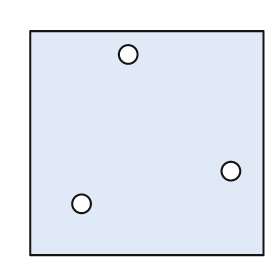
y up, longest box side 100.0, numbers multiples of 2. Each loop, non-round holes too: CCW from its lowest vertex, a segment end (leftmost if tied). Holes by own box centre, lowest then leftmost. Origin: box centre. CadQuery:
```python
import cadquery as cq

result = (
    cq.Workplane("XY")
    .moveTo(-50.0, -48.0)
    .lineTo(50.0, -48.0)
    .lineTo(50.0, 48.0)
    .lineTo(-50.0, 48.0)
    .close()
    .moveTo(-28.0, -26.0)
    .circle(4.0)
    .moveTo(36.0, -12.0)
    .circle(4.0)
    .moveTo(-8.0, 38.0)
    .circle(4.0)
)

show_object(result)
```